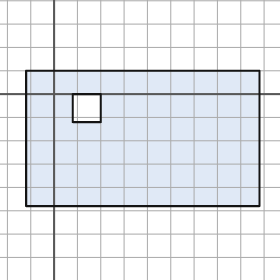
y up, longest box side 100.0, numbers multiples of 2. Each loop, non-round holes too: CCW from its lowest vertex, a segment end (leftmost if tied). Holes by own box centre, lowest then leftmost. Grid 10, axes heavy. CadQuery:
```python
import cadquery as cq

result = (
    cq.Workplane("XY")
    .moveTo(-12.0, -48.0)
    .lineTo(88.0, -48.0)
    .lineTo(88.0, 10.0)
    .lineTo(-12.0, 10.0)
    .close()
    .moveTo(8.0, -12.0)
    .lineTo(20.0, -12.0)
    .lineTo(20.0, 0.0)
    .lineTo(8.0, 0.0)
    .close()
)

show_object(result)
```